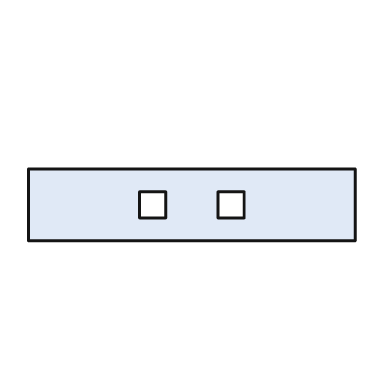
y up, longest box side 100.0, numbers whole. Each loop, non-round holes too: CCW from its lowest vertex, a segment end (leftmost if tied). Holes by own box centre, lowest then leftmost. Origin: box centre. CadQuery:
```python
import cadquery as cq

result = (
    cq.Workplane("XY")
    .moveTo(-50.0, -11.0)
    .lineTo(50.0, -11.0)
    .lineTo(50.0, 11.0)
    .lineTo(-50.0, 11.0)
    .close()
    .moveTo(-16.0, -4.0)
    .lineTo(-8.0, -4.0)
    .lineTo(-8.0, 4.0)
    .lineTo(-16.0, 4.0)
    .close()
    .moveTo(8.0, -4.0)
    .lineTo(16.0, -4.0)
    .lineTo(16.0, 4.0)
    .lineTo(8.0, 4.0)
    .close()
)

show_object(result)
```